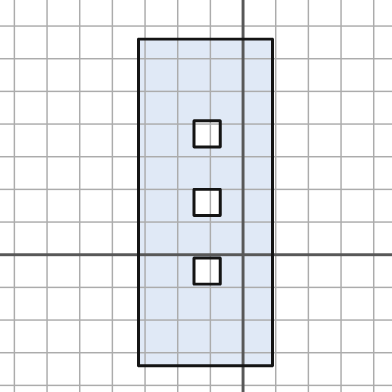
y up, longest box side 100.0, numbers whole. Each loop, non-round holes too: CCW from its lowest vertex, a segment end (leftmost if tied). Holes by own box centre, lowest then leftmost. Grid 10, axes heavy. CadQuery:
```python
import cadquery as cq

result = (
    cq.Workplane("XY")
    .moveTo(-32.0, -34.0)
    .lineTo(9.0, -34.0)
    .lineTo(9.0, 66.0)
    .lineTo(-32.0, 66.0)
    .close()
    .moveTo(-15.0, -9.0)
    .lineTo(-7.0, -9.0)
    .lineTo(-7.0, -1.0)
    .lineTo(-15.0, -1.0)
    .close()
    .moveTo(-15.0, 12.0)
    .lineTo(-7.0, 12.0)
    .lineTo(-7.0, 20.0)
    .lineTo(-15.0, 20.0)
    .close()
    .moveTo(-15.0, 33.0)
    .lineTo(-7.0, 33.0)
    .lineTo(-7.0, 41.0)
    .lineTo(-15.0, 41.0)
    .close()
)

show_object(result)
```